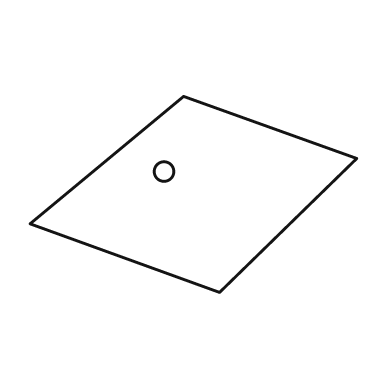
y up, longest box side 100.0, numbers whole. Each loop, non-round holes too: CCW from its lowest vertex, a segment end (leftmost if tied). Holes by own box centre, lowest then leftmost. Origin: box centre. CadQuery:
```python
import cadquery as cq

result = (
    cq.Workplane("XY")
    .moveTo(8.0, -30.0)
    .lineTo(50.0, 11.0)
    .lineTo(-3.0, 30.0)
    .lineTo(-50.0, -9.0)
    .close()
    .moveTo(-9.0, 7.0)
    .circle(3.0)
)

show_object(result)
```